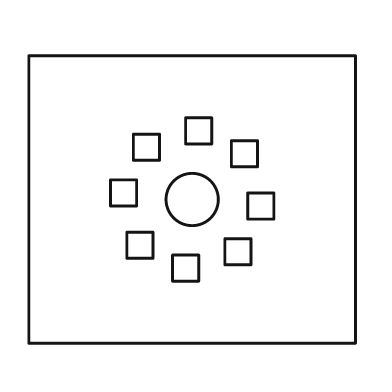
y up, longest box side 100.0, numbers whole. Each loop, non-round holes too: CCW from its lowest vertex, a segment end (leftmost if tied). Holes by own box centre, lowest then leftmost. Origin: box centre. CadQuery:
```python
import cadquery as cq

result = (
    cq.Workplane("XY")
    .moveTo(-50.0, -44.0)
    .lineTo(50.0, -44.0)
    .lineTo(50.0, 44.0)
    .lineTo(-50.0, 44.0)
    .close()
    .moveTo(-6.0, -25.0)
    .lineTo(2.0, -25.0)
    .lineTo(2.0, -17.0)
    .lineTo(-6.0, -17.0)
    .close()
    .moveTo(10.0, -20.0)
    .lineTo(18.0, -20.0)
    .lineTo(18.0, -12.0)
    .lineTo(10.0, -12.0)
    .close()
    .moveTo(-20.0, -18.0)
    .lineTo(-12.0, -18.0)
    .lineTo(-12.0, -10.0)
    .lineTo(-20.0, -10.0)
    .close()
    .moveTo(17.0, -6.0)
    .lineTo(25.0, -6.0)
    .lineTo(25.0, 2.0)
    .lineTo(17.0, 2.0)
    .close()
    .moveTo(0.0, 0.0)
    .circle(8.0)
    .moveTo(-25.0, -2.0)
    .lineTo(-17.0, -2.0)
    .lineTo(-17.0, 6.0)
    .lineTo(-25.0, 6.0)
    .close()
    .moveTo(12.0, 10.0)
    .lineTo(20.0, 10.0)
    .lineTo(20.0, 18.0)
    .lineTo(12.0, 18.0)
    .close()
    .moveTo(-18.0, 12.0)
    .lineTo(-10.0, 12.0)
    .lineTo(-10.0, 20.0)
    .lineTo(-18.0, 20.0)
    .close()
    .moveTo(-2.0, 17.0)
    .lineTo(6.0, 17.0)
    .lineTo(6.0, 25.0)
    .lineTo(-2.0, 25.0)
    .close()
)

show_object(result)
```